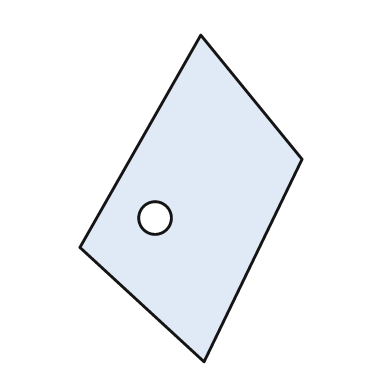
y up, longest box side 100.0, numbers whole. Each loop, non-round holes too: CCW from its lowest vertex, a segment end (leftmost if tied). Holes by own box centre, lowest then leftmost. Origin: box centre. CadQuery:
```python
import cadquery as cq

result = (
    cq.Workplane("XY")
    .moveTo(4.0, -50.0)
    .lineTo(34.0, 12.0)
    .lineTo(3.0, 50.0)
    .lineTo(-34.0, -15.0)
    .close()
    .moveTo(-11.0, -6.0)
    .circle(5.0)
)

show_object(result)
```